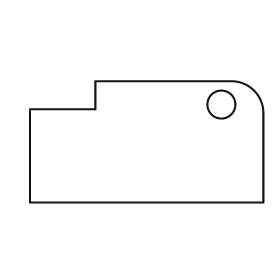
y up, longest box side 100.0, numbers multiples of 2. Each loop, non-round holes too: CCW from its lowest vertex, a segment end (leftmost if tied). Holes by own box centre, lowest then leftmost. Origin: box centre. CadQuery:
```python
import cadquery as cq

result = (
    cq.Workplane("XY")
    .moveTo(-50.0, -26.0)
    .lineTo(50.0, -26.0)
    .lineTo(50.0, 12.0)
    .threePointArc((46.0, 22.0), (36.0, 26.0))
    .lineTo(-22.0, 26.0)
    .lineTo(-22.0, 14.0)
    .lineTo(-50.0, 14.0)
    .close()
    .moveTo(32.0, 16.0)
    .circle(6.0)
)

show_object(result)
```